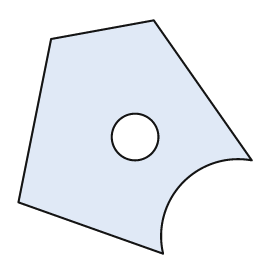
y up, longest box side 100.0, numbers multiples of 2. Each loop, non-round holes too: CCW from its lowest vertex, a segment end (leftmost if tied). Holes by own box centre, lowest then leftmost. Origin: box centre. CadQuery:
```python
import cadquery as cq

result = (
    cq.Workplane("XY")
    .moveTo(12.0, -50.0)
    .threePointArc((20.0, -20.0), (50.0, -10.0))
    .lineTo(8.0, 50.0)
    .lineTo(-36.0, 42.0)
    .lineTo(-50.0, -28.0)
    .close()
    .moveTo(0.0, 0.0)
    .circle(10.0)
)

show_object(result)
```